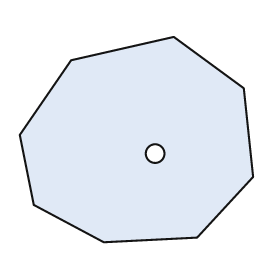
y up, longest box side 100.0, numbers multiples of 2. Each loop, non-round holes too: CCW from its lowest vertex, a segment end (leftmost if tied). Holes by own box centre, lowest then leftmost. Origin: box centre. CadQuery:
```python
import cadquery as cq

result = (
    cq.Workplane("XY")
    .moveTo(-14.0, -44.0)
    .lineTo(26.0, -42.0)
    .lineTo(50.0, -16.0)
    .lineTo(46.0, 22.0)
    .lineTo(16.0, 44.0)
    .lineTo(-28.0, 34.0)
    .lineTo(-50.0, 2.0)
    .lineTo(-44.0, -28.0)
    .close()
    .moveTo(8.0, -6.0)
    .circle(4.0)
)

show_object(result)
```